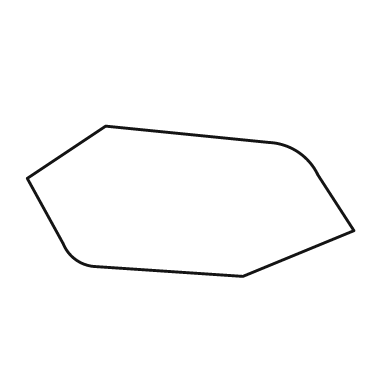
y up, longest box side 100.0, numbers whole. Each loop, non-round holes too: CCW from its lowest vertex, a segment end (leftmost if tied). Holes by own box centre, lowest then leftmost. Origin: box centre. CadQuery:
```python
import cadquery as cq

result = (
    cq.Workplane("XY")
    .moveTo(16.0, -23.0)
    .lineTo(50.0, -9.0)
    .lineTo(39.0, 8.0)
    .threePointArc((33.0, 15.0), (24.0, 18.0))
    .lineTo(-26.0, 23.0)
    .lineTo(-50.0, 7.0)
    .lineTo(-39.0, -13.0)
    .threePointArc((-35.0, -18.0), (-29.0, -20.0))
    .close()
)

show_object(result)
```